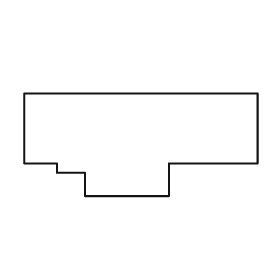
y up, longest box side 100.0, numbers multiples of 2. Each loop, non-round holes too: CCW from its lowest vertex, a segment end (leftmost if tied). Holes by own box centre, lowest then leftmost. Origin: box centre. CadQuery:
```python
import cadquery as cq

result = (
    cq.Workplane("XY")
    .moveTo(-24.0, -22.0)
    .lineTo(12.0, -22.0)
    .lineTo(12.0, -8.0)
    .lineTo(50.0, -8.0)
    .lineTo(50.0, 22.0)
    .lineTo(-50.0, 22.0)
    .lineTo(-50.0, -8.0)
    .lineTo(-36.0, -8.0)
    .lineTo(-36.0, -12.0)
    .lineTo(-24.0, -12.0)
    .close()
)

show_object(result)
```